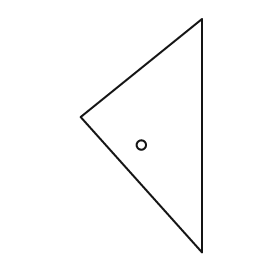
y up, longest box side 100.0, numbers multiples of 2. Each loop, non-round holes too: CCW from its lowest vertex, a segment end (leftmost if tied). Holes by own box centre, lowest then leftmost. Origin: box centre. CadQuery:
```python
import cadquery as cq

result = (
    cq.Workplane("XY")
    .moveTo(26.0, -50.0)
    .lineTo(26.0, 50.0)
    .lineTo(-26.0, 8.0)
    .close()
    .moveTo(0.0, -4.0)
    .circle(2.0)
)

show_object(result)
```